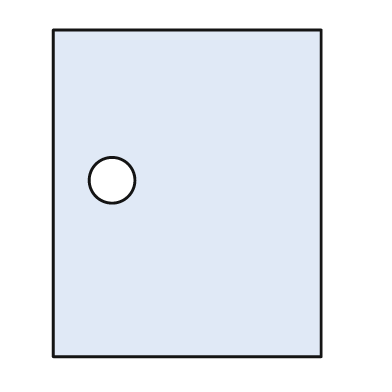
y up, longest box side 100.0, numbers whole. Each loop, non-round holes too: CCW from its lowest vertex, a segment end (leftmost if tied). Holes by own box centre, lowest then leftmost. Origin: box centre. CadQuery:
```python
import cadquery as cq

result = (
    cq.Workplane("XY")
    .moveTo(-41.0, -50.0)
    .lineTo(41.0, -50.0)
    .lineTo(41.0, 50.0)
    .lineTo(-41.0, 50.0)
    .close()
    .moveTo(-23.0, 4.0)
    .circle(7.0)
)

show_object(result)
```